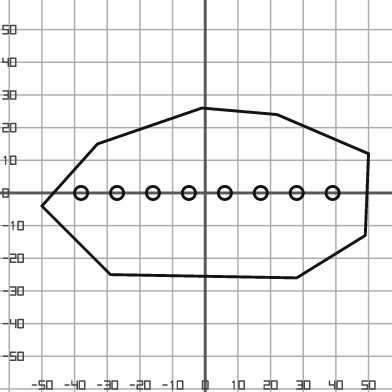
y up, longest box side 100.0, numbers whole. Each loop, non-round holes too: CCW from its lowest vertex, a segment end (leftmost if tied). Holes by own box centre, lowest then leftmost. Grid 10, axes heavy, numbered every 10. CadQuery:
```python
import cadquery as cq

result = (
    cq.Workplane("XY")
    .moveTo(28.0, -26.0)
    .lineTo(49.0, -13.0)
    .lineTo(50.0, 12.0)
    .lineTo(22.0, 24.0)
    .lineTo(-1.0, 26.0)
    .lineTo(-33.0, 15.0)
    .lineTo(-50.0, -4.0)
    .lineTo(-29.0, -25.0)
    .close()
    .moveTo(-38.0, 0.0)
    .circle(2.0)
    .moveTo(-27.0, 0.0)
    .circle(2.0)
    .moveTo(-16.0, 0.0)
    .circle(2.0)
    .moveTo(-5.0, 0.0)
    .circle(2.0)
    .moveTo(6.0, 0.0)
    .circle(2.0)
    .moveTo(17.0, 0.0)
    .circle(2.0)
    .moveTo(28.0, 0.0)
    .circle(2.0)
    .moveTo(39.0, 0.0)
    .circle(2.0)
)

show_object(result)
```